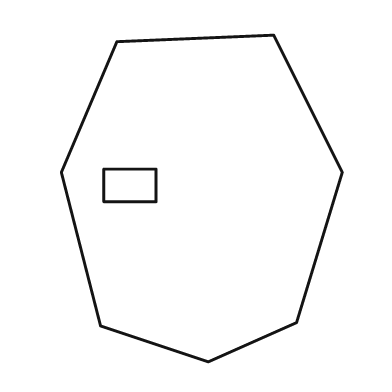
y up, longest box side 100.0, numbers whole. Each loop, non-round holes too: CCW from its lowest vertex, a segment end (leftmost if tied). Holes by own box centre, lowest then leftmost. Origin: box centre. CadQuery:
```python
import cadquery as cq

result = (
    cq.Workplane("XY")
    .moveTo(2.0, -50.0)
    .lineTo(29.0, -38.0)
    .lineTo(43.0, 8.0)
    .lineTo(22.0, 50.0)
    .lineTo(-26.0, 48.0)
    .lineTo(-43.0, 8.0)
    .lineTo(-31.0, -39.0)
    .close()
    .moveTo(-30.0, -1.0)
    .lineTo(-14.0, -1.0)
    .lineTo(-14.0, 9.0)
    .lineTo(-30.0, 9.0)
    .close()
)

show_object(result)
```